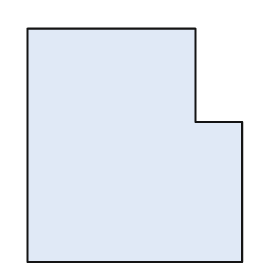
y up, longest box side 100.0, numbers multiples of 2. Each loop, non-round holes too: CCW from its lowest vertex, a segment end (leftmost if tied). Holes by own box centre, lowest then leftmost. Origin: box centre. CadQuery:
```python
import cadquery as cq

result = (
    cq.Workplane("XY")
    .moveTo(-46.0, -50.0)
    .lineTo(46.0, -50.0)
    .lineTo(46.0, 10.0)
    .lineTo(26.0, 10.0)
    .lineTo(26.0, 50.0)
    .lineTo(-46.0, 50.0)
    .close()
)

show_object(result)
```